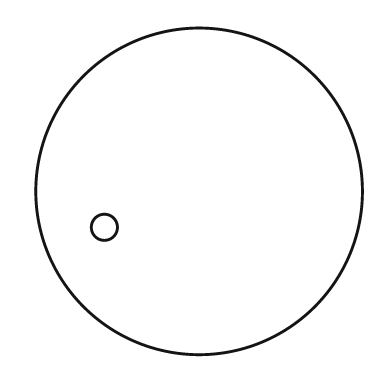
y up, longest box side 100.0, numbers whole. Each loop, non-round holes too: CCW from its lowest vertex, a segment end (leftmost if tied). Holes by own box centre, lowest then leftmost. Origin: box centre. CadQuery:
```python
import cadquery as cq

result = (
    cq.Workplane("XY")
    .moveTo(0.0, 0.0)
    .circle(50.0)
    .moveTo(-29.0, -11.0)
    .circle(4.0)
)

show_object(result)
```